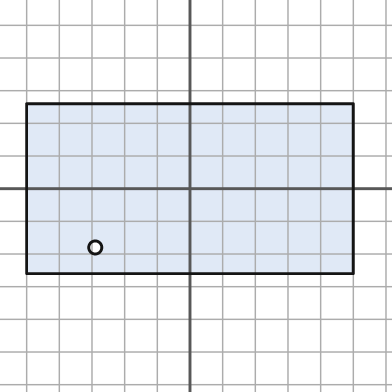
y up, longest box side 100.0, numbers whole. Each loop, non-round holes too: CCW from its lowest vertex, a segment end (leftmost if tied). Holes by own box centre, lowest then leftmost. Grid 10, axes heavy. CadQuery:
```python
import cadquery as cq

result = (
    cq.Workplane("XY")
    .moveTo(-50.0, -26.0)
    .lineTo(50.0, -26.0)
    .lineTo(50.0, 26.0)
    .lineTo(-50.0, 26.0)
    .close()
    .moveTo(-29.0, -18.0)
    .circle(2.0)
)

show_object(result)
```